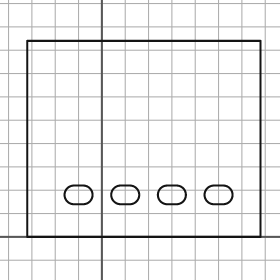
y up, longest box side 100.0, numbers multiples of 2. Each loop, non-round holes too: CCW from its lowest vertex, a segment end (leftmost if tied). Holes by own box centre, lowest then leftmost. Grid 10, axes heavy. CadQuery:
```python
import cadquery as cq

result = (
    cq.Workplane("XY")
    .moveTo(-32.0, 0.0)
    .lineTo(68.0, 0.0)
    .lineTo(68.0, 84.0)
    .lineTo(-32.0, 84.0)
    .close()
    .moveTo(-12.0, 14.0)
    .lineTo(-8.0, 14.0)
    .threePointArc((-4.0, 18.0), (-8.0, 22.0))
    .lineTo(-12.0, 22.0)
    .threePointArc((-16.0, 18.0), (-12.0, 14.0))
    .close()
    .moveTo(8.0, 14.0)
    .lineTo(12.0, 14.0)
    .threePointArc((16.0, 18.0), (12.0, 22.0))
    .lineTo(8.0, 22.0)
    .threePointArc((4.0, 18.0), (8.0, 14.0))
    .close()
    .moveTo(28.0, 14.0)
    .lineTo(32.0, 14.0)
    .threePointArc((36.0, 18.0), (32.0, 22.0))
    .lineTo(28.0, 22.0)
    .threePointArc((24.0, 18.0), (28.0, 14.0))
    .close()
    .moveTo(48.0, 14.0)
    .lineTo(52.0, 14.0)
    .threePointArc((56.0, 18.0), (52.0, 22.0))
    .lineTo(48.0, 22.0)
    .threePointArc((44.0, 18.0), (48.0, 14.0))
    .close()
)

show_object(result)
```